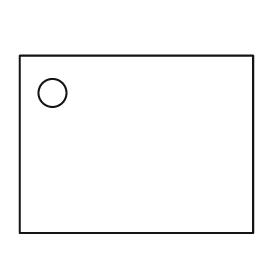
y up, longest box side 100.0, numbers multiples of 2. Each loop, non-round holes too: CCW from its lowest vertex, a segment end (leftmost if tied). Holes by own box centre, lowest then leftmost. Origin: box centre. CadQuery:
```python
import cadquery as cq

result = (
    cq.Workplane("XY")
    .moveTo(-50.0, -38.0)
    .lineTo(50.0, -38.0)
    .lineTo(50.0, 38.0)
    .lineTo(-50.0, 38.0)
    .close()
    .moveTo(-36.0, 22.0)
    .circle(6.0)
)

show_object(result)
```